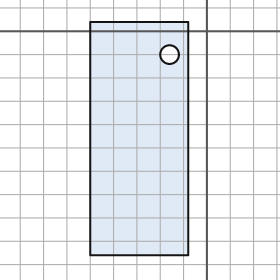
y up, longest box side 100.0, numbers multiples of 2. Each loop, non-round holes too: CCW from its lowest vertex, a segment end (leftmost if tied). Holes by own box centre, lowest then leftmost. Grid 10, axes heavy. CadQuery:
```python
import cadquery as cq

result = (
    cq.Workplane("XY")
    .moveTo(-50.0, -96.0)
    .lineTo(-8.0, -96.0)
    .lineTo(-8.0, 4.0)
    .lineTo(-50.0, 4.0)
    .close()
    .moveTo(-16.0, -10.0)
    .circle(4.0)
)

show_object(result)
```